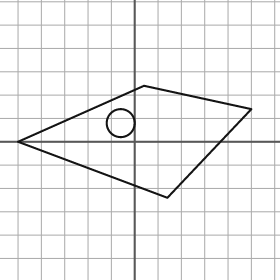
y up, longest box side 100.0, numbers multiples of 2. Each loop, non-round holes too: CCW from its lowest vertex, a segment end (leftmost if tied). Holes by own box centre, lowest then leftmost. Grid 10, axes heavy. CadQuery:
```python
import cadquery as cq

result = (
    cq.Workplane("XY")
    .moveTo(14.0, -24.0)
    .lineTo(50.0, 14.0)
    .lineTo(4.0, 24.0)
    .lineTo(-50.0, 0.0)
    .close()
    .moveTo(-6.0, 8.0)
    .circle(6.0)
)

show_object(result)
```